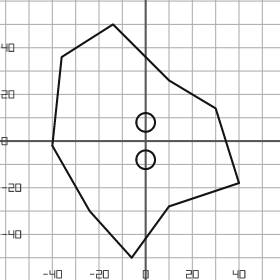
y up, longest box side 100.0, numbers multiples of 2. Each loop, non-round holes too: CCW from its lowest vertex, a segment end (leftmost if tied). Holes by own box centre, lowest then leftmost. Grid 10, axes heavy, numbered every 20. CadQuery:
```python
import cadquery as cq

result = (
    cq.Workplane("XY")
    .moveTo(-6.0, -50.0)
    .lineTo(10.0, -28.0)
    .lineTo(40.0, -18.0)
    .lineTo(30.0, 14.0)
    .lineTo(10.0, 26.0)
    .lineTo(-14.0, 50.0)
    .lineTo(-36.0, 36.0)
    .lineTo(-40.0, -2.0)
    .lineTo(-24.0, -30.0)
    .close()
    .moveTo(0.0, -8.0)
    .circle(4.0)
    .moveTo(0.0, 8.0)
    .circle(4.0)
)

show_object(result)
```